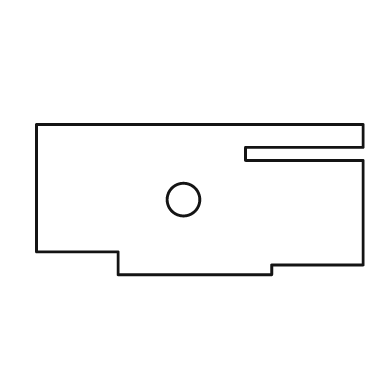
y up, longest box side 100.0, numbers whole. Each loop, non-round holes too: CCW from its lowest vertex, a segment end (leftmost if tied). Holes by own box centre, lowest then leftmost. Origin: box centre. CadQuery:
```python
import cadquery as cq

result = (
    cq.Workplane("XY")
    .moveTo(-25.0, -23.0)
    .lineTo(22.0, -23.0)
    .lineTo(22.0, -20.0)
    .lineTo(50.0, -20.0)
    .lineTo(50.0, 12.0)
    .lineTo(14.0, 12.0)
    .lineTo(14.0, 16.0)
    .lineTo(50.0, 16.0)
    .lineTo(50.0, 23.0)
    .lineTo(-50.0, 23.0)
    .lineTo(-50.0, -16.0)
    .lineTo(-25.0, -16.0)
    .close()
    .moveTo(-5.0, 0.0)
    .circle(5.0)
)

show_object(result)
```